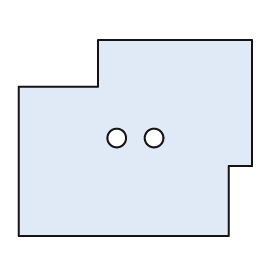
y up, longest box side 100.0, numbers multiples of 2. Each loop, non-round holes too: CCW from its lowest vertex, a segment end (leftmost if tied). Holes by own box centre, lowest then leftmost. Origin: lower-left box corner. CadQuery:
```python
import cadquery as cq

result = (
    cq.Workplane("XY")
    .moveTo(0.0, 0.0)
    .lineTo(90.0, 0.0)
    .lineTo(90.0, 30.0)
    .lineTo(100.0, 30.0)
    .lineTo(100.0, 84.0)
    .lineTo(34.0, 84.0)
    .lineTo(34.0, 64.0)
    .lineTo(0.0, 64.0)
    .close()
    .moveTo(42.0, 42.0)
    .circle(4.0)
    .moveTo(58.0, 42.0)
    .circle(4.0)
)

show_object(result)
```